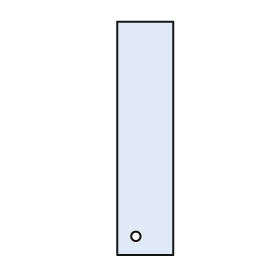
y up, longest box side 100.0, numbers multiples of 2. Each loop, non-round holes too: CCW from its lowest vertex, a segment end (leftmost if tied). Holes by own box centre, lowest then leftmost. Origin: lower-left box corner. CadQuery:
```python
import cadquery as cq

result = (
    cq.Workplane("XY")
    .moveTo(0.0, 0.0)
    .lineTo(24.0, 0.0)
    .lineTo(24.0, 100.0)
    .lineTo(0.0, 100.0)
    .close()
    .moveTo(8.0, 8.0)
    .circle(2.0)
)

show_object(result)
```